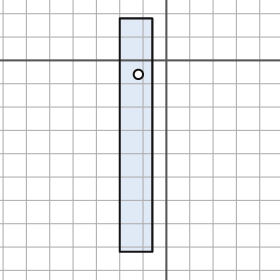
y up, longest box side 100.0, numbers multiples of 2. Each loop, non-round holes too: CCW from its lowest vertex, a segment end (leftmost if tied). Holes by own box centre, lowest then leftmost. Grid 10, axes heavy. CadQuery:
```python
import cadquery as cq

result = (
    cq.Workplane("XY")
    .moveTo(-20.0, -82.0)
    .lineTo(-6.0, -82.0)
    .lineTo(-6.0, 18.0)
    .lineTo(-20.0, 18.0)
    .close()
    .moveTo(-12.0, -6.0)
    .circle(2.0)
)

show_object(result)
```